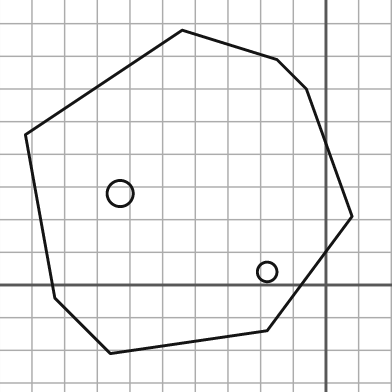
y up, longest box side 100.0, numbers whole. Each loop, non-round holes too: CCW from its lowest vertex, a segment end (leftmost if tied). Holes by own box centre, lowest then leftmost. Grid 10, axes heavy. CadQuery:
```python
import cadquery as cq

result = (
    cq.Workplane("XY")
    .moveTo(-66.0, -21.0)
    .lineTo(-18.0, -14.0)
    .lineTo(8.0, 21.0)
    .lineTo(-6.0, 60.0)
    .lineTo(-15.0, 69.0)
    .lineTo(-44.0, 78.0)
    .lineTo(-92.0, 46.0)
    .lineTo(-83.0, -4.0)
    .close()
    .moveTo(-18.0, 4.0)
    .circle(3.0)
    .moveTo(-63.0, 28.0)
    .circle(4.0)
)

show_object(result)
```